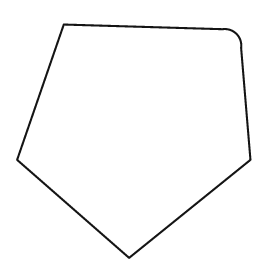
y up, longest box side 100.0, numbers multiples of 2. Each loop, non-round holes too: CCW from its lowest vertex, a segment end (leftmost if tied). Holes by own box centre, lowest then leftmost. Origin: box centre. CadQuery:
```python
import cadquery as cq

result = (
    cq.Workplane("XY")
    .moveTo(-2.0, -50.0)
    .lineTo(50.0, -8.0)
    .lineTo(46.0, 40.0)
    .threePointArc((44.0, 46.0), (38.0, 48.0))
    .lineTo(-30.0, 50.0)
    .lineTo(-50.0, -8.0)
    .close()
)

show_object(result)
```